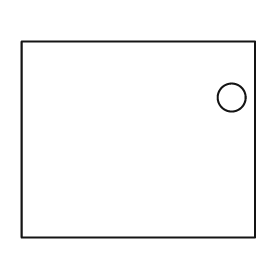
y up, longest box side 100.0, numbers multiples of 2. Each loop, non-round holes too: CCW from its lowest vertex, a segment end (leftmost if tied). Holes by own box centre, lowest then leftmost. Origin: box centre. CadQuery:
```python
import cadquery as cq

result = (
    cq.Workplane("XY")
    .moveTo(-50.0, -42.0)
    .lineTo(50.0, -42.0)
    .lineTo(50.0, 42.0)
    .lineTo(-50.0, 42.0)
    .close()
    .moveTo(40.0, 18.0)
    .circle(6.0)
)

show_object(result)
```